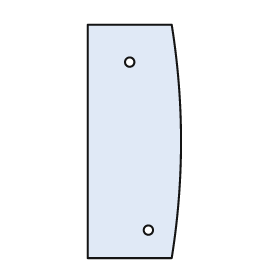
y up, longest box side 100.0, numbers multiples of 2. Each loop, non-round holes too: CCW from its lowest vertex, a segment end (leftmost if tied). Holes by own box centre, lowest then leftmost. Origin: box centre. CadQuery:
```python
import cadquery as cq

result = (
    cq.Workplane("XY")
    .moveTo(-20.0, -50.0)
    .lineTo(16.0, -50.0)
    .threePointArc((20.0, 0.0), (16.0, 50.0))
    .lineTo(-20.0, 50.0)
    .close()
    .moveTo(6.0, -38.0)
    .circle(2.0)
    .moveTo(-2.0, 34.0)
    .circle(2.0)
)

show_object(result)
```